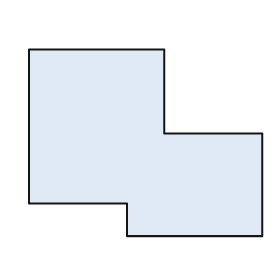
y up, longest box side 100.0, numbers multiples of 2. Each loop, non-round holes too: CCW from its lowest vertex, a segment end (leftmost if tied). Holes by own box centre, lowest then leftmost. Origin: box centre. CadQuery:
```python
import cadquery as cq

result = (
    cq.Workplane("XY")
    .moveTo(-8.0, -40.0)
    .lineTo(50.0, -40.0)
    .lineTo(50.0, 4.0)
    .lineTo(8.0, 4.0)
    .lineTo(8.0, 40.0)
    .lineTo(-50.0, 40.0)
    .lineTo(-50.0, -26.0)
    .lineTo(-8.0, -26.0)
    .close()
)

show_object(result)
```